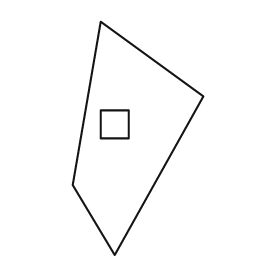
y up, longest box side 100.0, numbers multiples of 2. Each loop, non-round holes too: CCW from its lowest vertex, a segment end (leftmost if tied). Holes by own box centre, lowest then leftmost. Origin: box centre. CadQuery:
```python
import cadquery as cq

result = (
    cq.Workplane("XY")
    .moveTo(-10.0, -50.0)
    .lineTo(28.0, 18.0)
    .lineTo(-16.0, 50.0)
    .lineTo(-28.0, -20.0)
    .close()
    .moveTo(-16.0, 0.0)
    .lineTo(-4.0, 0.0)
    .lineTo(-4.0, 12.0)
    .lineTo(-16.0, 12.0)
    .close()
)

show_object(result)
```